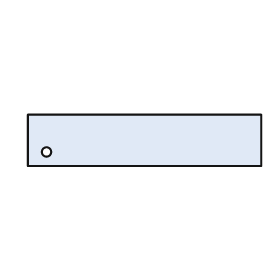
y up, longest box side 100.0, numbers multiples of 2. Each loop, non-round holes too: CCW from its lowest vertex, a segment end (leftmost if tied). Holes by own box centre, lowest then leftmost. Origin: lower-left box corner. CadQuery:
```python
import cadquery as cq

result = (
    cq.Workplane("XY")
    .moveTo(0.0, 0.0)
    .lineTo(100.0, 0.0)
    .lineTo(100.0, 22.0)
    .lineTo(0.0, 22.0)
    .close()
    .moveTo(8.0, 6.0)
    .circle(2.0)
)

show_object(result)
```